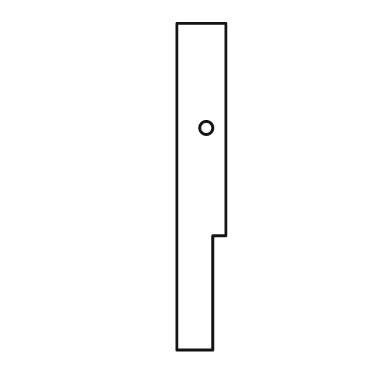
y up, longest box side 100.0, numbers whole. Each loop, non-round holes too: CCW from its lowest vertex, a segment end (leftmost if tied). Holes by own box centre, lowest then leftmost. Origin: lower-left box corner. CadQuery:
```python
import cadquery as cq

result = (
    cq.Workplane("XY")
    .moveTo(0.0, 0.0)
    .lineTo(11.0, 0.0)
    .lineTo(11.0, 35.0)
    .lineTo(15.0, 35.0)
    .lineTo(15.0, 100.0)
    .lineTo(0.0, 100.0)
    .close()
    .moveTo(9.0, 68.0)
    .circle(2.0)
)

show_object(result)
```